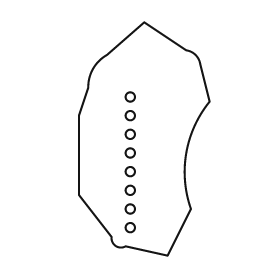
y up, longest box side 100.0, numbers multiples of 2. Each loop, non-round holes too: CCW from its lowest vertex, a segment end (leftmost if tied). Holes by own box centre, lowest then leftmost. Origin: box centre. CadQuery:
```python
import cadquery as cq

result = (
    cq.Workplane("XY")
    .moveTo(10.0, -50.0)
    .lineTo(20.0, -30.0)
    .threePointArc((18.0, -6.0), (28.0, 16.0))
    .lineTo(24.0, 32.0)
    .threePointArc((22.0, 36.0), (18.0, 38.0))
    .lineTo(0.0, 50.0)
    .lineTo(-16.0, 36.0)
    .threePointArc((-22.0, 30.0), (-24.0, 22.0))
    .lineTo(-28.0, 10.0)
    .lineTo(-28.0, -24.0)
    .lineTo(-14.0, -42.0)
    .threePointArc((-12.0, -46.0), (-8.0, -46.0))
    .close()
    .moveTo(-6.0, -38.0)
    .circle(2.0)
    .moveTo(-6.0, -30.0)
    .circle(2.0)
    .moveTo(-6.0, -22.0)
    .circle(2.0)
    .moveTo(-6.0, -14.0)
    .circle(2.0)
    .moveTo(-6.0, -6.0)
    .circle(2.0)
    .moveTo(-6.0, 2.0)
    .circle(2.0)
    .moveTo(-6.0, 10.0)
    .circle(2.0)
    .moveTo(-6.0, 18.0)
    .circle(2.0)
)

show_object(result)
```